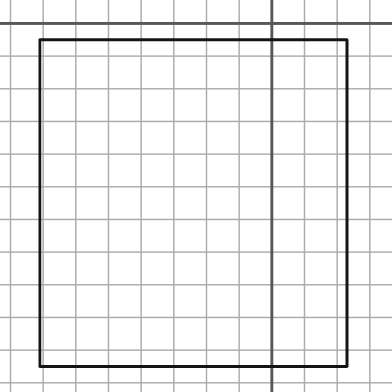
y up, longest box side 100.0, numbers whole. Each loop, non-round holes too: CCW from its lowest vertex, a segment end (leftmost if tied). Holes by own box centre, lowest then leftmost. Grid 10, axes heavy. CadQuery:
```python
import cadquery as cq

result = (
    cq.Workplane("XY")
    .moveTo(-71.0, -105.0)
    .lineTo(23.0, -105.0)
    .lineTo(23.0, -5.0)
    .lineTo(-71.0, -5.0)
    .close()
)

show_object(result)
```